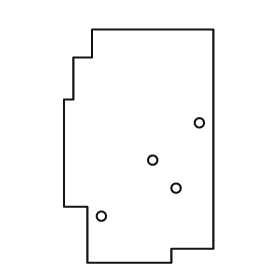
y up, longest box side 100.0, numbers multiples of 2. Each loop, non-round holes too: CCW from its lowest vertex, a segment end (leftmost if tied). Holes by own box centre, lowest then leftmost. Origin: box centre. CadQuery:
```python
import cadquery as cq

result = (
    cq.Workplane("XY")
    .moveTo(-22.0, -50.0)
    .lineTo(14.0, -50.0)
    .lineTo(14.0, -44.0)
    .lineTo(32.0, -44.0)
    .lineTo(32.0, 50.0)
    .lineTo(-20.0, 50.0)
    .lineTo(-20.0, 38.0)
    .lineTo(-28.0, 38.0)
    .lineTo(-28.0, 20.0)
    .lineTo(-32.0, 20.0)
    .lineTo(-32.0, -26.0)
    .lineTo(-22.0, -26.0)
    .close()
    .moveTo(-16.0, -30.0)
    .circle(2.0)
    .moveTo(16.0, -18.0)
    .circle(2.0)
    .moveTo(6.0, -6.0)
    .circle(2.0)
    .moveTo(26.0, 10.0)
    .circle(2.0)
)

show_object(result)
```